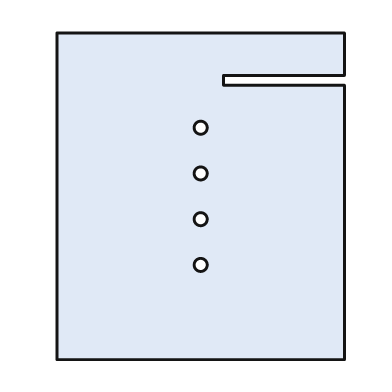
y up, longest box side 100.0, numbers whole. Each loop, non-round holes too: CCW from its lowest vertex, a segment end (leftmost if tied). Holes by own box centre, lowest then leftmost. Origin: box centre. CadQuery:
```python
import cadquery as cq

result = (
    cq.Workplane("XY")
    .moveTo(-44.0, -50.0)
    .lineTo(44.0, -50.0)
    .lineTo(44.0, 34.0)
    .lineTo(7.0, 34.0)
    .lineTo(7.0, 37.0)
    .lineTo(44.0, 37.0)
    .lineTo(44.0, 50.0)
    .lineTo(-44.0, 50.0)
    .close()
    .moveTo(0.0, -21.0)
    .circle(2.0)
    .moveTo(0.0, -7.0)
    .circle(2.0)
    .moveTo(0.0, 7.0)
    .circle(2.0)
    .moveTo(0.0, 21.0)
    .circle(2.0)
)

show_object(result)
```